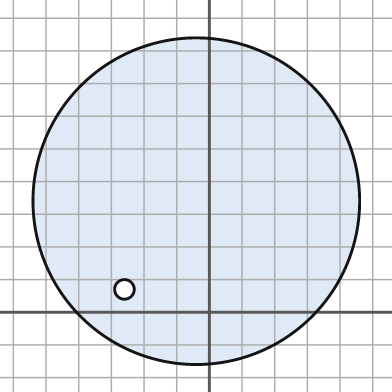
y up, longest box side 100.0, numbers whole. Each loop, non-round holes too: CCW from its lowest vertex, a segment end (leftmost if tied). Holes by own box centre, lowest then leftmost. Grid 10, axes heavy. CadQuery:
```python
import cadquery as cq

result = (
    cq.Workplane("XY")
    .moveTo(-4.0, 34.0)
    .circle(50.0)
    .moveTo(-26.0, 7.0)
    .circle(3.0)
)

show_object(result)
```